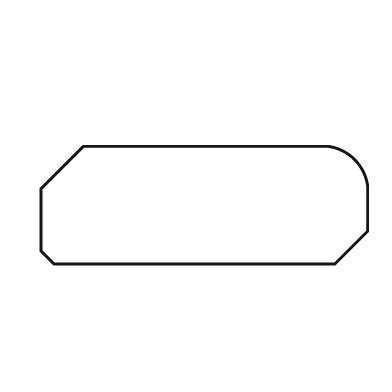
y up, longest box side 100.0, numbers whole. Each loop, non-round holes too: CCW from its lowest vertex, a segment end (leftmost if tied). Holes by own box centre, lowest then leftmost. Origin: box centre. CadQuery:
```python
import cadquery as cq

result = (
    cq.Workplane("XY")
    .moveTo(-46.0, -18.0)
    .lineTo(40.0, -18.0)
    .lineTo(50.0, -8.0)
    .lineTo(50.0, 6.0)
    .threePointArc((46.0, 14.0), (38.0, 18.0))
    .lineTo(-37.0, 18.0)
    .lineTo(-50.0, 5.0)
    .lineTo(-50.0, -14.0)
    .close()
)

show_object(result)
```